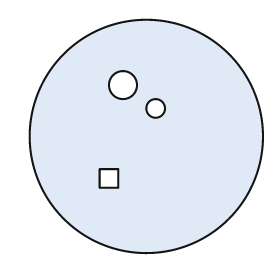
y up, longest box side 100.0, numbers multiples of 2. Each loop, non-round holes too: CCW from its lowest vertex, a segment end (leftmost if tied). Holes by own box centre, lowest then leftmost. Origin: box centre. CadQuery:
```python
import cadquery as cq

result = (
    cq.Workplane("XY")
    .moveTo(0.0, 0.0)
    .circle(50.0)
    .moveTo(-20.0, -22.0)
    .lineTo(-12.0, -22.0)
    .lineTo(-12.0, -14.0)
    .lineTo(-20.0, -14.0)
    .close()
    .moveTo(4.0, 12.0)
    .circle(4.0)
    .moveTo(-10.0, 22.0)
    .circle(6.0)
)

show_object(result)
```